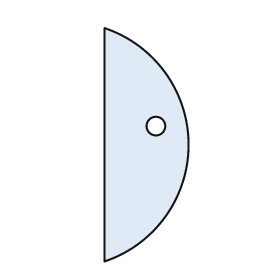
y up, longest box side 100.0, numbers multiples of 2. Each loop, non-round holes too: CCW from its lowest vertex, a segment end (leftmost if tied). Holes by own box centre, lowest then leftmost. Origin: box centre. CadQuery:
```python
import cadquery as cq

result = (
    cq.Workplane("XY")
    .moveTo(-18.0, -50.0)
    .threePointArc((18.0, 0.0), (-18.0, 50.0))
    .close()
    .moveTo(4.0, 8.0)
    .circle(4.0)
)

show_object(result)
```